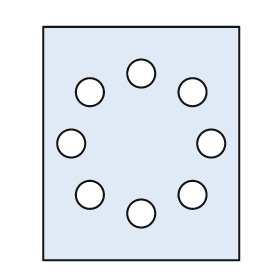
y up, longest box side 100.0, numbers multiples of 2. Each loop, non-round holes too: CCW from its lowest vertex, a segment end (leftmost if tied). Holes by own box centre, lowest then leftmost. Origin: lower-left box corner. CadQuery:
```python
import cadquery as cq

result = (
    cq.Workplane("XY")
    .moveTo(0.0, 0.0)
    .lineTo(84.0, 0.0)
    .lineTo(84.0, 100.0)
    .lineTo(0.0, 100.0)
    .close()
    .moveTo(42.0, 20.0)
    .circle(6.0)
    .moveTo(20.0, 28.0)
    .circle(6.0)
    .moveTo(64.0, 28.0)
    .circle(6.0)
    .moveTo(12.0, 50.0)
    .circle(6.0)
    .moveTo(72.0, 50.0)
    .circle(6.0)
    .moveTo(20.0, 72.0)
    .circle(6.0)
    .moveTo(64.0, 72.0)
    .circle(6.0)
    .moveTo(42.0, 80.0)
    .circle(6.0)
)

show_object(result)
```